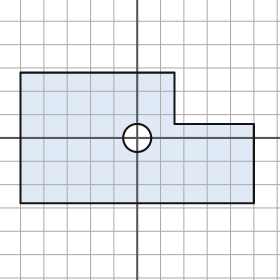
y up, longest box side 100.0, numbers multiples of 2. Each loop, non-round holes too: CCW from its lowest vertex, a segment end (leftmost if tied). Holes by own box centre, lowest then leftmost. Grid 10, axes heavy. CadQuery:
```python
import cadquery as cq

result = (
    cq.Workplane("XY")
    .moveTo(-50.0, -28.0)
    .lineTo(50.0, -28.0)
    .lineTo(50.0, 6.0)
    .lineTo(16.0, 6.0)
    .lineTo(16.0, 28.0)
    .lineTo(-50.0, 28.0)
    .close()
    .moveTo(0.0, 0.0)
    .circle(6.0)
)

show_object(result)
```